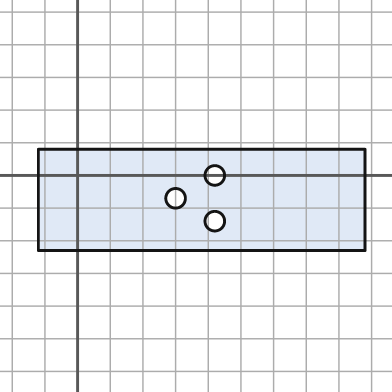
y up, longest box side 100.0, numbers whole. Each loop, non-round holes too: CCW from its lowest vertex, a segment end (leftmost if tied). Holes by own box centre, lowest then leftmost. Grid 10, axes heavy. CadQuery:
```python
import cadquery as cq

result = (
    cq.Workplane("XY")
    .moveTo(-12.0, -23.0)
    .lineTo(88.0, -23.0)
    .lineTo(88.0, 8.0)
    .lineTo(-12.0, 8.0)
    .close()
    .moveTo(42.0, -14.0)
    .circle(3.0)
    .moveTo(30.0, -7.0)
    .circle(3.0)
    .moveTo(42.0, 0.0)
    .circle(3.0)
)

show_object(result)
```